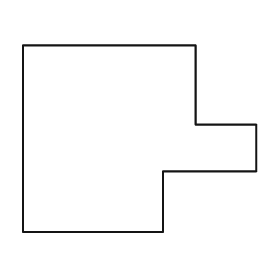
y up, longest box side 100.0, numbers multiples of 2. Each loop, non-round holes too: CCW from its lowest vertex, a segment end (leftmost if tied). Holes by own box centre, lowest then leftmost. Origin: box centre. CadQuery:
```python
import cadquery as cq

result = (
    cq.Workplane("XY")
    .moveTo(-50.0, -40.0)
    .lineTo(10.0, -40.0)
    .lineTo(10.0, -14.0)
    .lineTo(50.0, -14.0)
    .lineTo(50.0, 6.0)
    .lineTo(24.0, 6.0)
    .lineTo(24.0, 40.0)
    .lineTo(-50.0, 40.0)
    .close()
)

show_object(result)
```